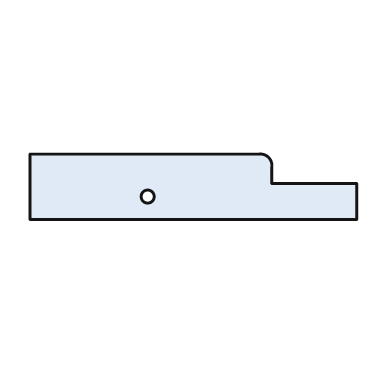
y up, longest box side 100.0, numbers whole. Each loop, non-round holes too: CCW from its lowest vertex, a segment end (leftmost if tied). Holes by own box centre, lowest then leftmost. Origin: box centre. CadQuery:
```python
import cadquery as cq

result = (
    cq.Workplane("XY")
    .moveTo(-50.0, -10.0)
    .lineTo(50.0, -10.0)
    .lineTo(50.0, 1.0)
    .lineTo(24.0, 1.0)
    .lineTo(24.0, 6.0)
    .threePointArc((23.0, 9.0), (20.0, 10.0))
    .lineTo(-50.0, 10.0)
    .close()
    .moveTo(-14.0, -3.0)
    .circle(2.0)
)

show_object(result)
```